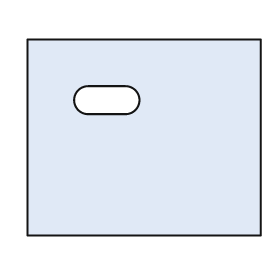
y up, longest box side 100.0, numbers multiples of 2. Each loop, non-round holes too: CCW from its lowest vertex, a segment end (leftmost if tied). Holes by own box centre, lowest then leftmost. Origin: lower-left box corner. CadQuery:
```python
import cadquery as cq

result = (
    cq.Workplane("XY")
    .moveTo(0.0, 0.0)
    .lineTo(100.0, 0.0)
    .lineTo(100.0, 84.0)
    .lineTo(0.0, 84.0)
    .close()
    .moveTo(26.0, 52.0)
    .lineTo(42.0, 52.0)
    .threePointArc((48.0, 58.0), (42.0, 64.0))
    .lineTo(26.0, 64.0)
    .threePointArc((20.0, 58.0), (26.0, 52.0))
    .close()
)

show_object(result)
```